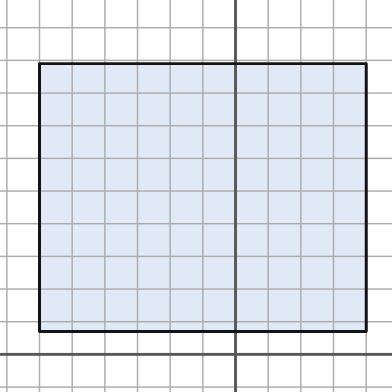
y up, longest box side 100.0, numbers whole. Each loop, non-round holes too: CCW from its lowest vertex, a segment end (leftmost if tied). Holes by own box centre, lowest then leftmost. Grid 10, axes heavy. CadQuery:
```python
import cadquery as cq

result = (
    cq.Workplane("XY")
    .moveTo(-60.0, 7.0)
    .lineTo(40.0, 7.0)
    .lineTo(40.0, 89.0)
    .lineTo(-60.0, 89.0)
    .close()
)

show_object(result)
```